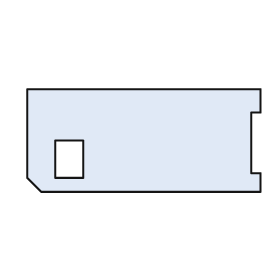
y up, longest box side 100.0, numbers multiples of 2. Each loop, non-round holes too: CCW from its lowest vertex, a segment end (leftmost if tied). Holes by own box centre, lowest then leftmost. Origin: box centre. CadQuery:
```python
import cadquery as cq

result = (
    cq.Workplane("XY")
    .moveTo(-44.0, -22.0)
    .lineTo(50.0, -22.0)
    .lineTo(50.0, -14.0)
    .lineTo(46.0, -14.0)
    .lineTo(46.0, 12.0)
    .lineTo(50.0, 12.0)
    .lineTo(50.0, 22.0)
    .lineTo(-50.0, 22.0)
    .lineTo(-50.0, -16.0)
    .close()
    .moveTo(-38.0, -16.0)
    .lineTo(-26.0, -16.0)
    .lineTo(-26.0, 0.0)
    .lineTo(-38.0, 0.0)
    .close()
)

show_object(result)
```